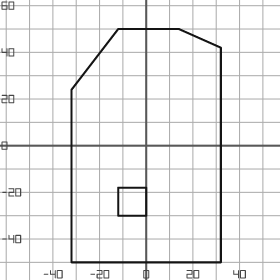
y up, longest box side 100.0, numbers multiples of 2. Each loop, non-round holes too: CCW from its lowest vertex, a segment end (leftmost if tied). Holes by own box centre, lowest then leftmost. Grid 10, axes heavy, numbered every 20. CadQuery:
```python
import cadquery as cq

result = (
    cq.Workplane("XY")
    .moveTo(-32.0, -50.0)
    .lineTo(32.0, -50.0)
    .lineTo(32.0, 42.0)
    .lineTo(14.0, 50.0)
    .lineTo(-12.0, 50.0)
    .lineTo(-32.0, 24.0)
    .close()
    .moveTo(-12.0, -30.0)
    .lineTo(0.0, -30.0)
    .lineTo(0.0, -18.0)
    .lineTo(-12.0, -18.0)
    .close()
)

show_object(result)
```